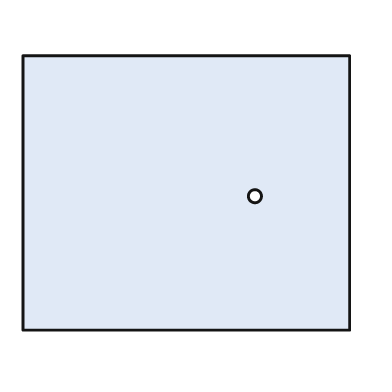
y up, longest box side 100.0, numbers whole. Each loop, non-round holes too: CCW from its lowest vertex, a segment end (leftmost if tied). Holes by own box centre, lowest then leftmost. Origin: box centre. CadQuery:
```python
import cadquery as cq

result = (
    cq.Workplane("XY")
    .moveTo(-50.0, -42.0)
    .lineTo(50.0, -42.0)
    .lineTo(50.0, 42.0)
    .lineTo(-50.0, 42.0)
    .close()
    .moveTo(21.0, -1.0)
    .circle(2.0)
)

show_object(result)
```